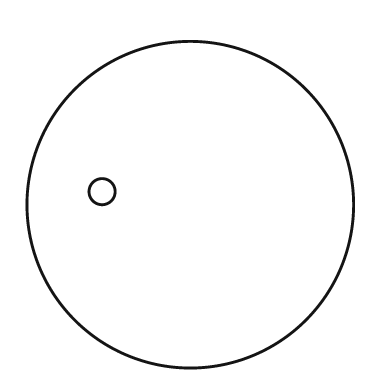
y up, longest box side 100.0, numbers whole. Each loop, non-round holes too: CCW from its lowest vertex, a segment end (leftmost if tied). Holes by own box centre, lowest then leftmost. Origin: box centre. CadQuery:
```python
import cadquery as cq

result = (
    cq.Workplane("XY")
    .moveTo(0.0, 0.0)
    .circle(50.0)
    .moveTo(-27.0, 4.0)
    .circle(4.0)
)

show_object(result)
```